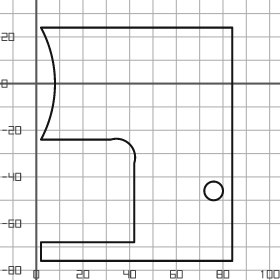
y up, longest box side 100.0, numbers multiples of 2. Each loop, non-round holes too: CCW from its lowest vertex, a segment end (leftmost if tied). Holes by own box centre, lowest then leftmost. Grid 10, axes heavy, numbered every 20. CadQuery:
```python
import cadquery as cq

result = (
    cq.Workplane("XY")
    .moveTo(2.0, -76.0)
    .lineTo(84.0, -76.0)
    .lineTo(84.0, 24.0)
    .lineTo(2.0, 24.0)
    .threePointArc((8.0, 0.0), (2.0, -24.0))
    .lineTo(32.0, -24.0)
    .threePointArc((40.0, -26.0), (42.0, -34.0))
    .lineTo(42.0, -68.0)
    .lineTo(2.0, -68.0)
    .close()
    .moveTo(76.0, -46.0)
    .circle(4.0)
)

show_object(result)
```